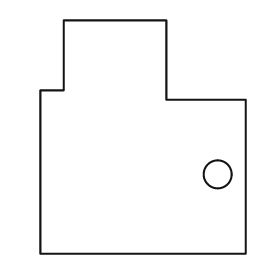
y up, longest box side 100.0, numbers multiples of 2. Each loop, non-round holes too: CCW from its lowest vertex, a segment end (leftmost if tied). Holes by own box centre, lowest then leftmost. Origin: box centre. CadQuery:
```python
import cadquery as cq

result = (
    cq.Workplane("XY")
    .moveTo(-44.0, -50.0)
    .lineTo(44.0, -50.0)
    .lineTo(44.0, 16.0)
    .lineTo(10.0, 16.0)
    .lineTo(10.0, 50.0)
    .lineTo(-34.0, 50.0)
    .lineTo(-34.0, 20.0)
    .lineTo(-44.0, 20.0)
    .close()
    .moveTo(32.0, -16.0)
    .circle(6.0)
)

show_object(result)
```